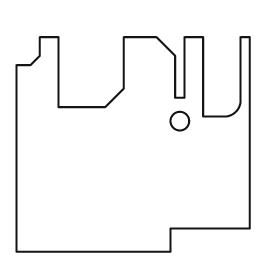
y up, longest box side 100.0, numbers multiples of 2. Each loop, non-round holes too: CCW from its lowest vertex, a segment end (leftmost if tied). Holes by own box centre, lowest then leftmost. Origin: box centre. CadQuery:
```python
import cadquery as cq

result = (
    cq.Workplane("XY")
    .moveTo(-50.0, -46.0)
    .lineTo(16.0, -46.0)
    .lineTo(16.0, -36.0)
    .lineTo(50.0, -36.0)
    .lineTo(50.0, 46.0)
    .lineTo(46.0, 46.0)
    .lineTo(46.0, 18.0)
    .threePointArc((44.0, 14.0), (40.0, 12.0))
    .lineTo(30.0, 12.0)
    .lineTo(30.0, 46.0)
    .lineTo(22.0, 46.0)
    .lineTo(22.0, 20.0)
    .lineTo(18.0, 20.0)
    .lineTo(18.0, 38.0)
    .lineTo(10.0, 46.0)
    .lineTo(-4.0, 46.0)
    .lineTo(-4.0, 24.0)
    .lineTo(-12.0, 16.0)
    .lineTo(-32.0, 16.0)
    .lineTo(-32.0, 46.0)
    .lineTo(-40.0, 46.0)
    .lineTo(-40.0, 38.0)
    .lineTo(-44.0, 34.0)
    .lineTo(-50.0, 34.0)
    .close()
    .moveTo(20.0, 10.0)
    .circle(4.0)
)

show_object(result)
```